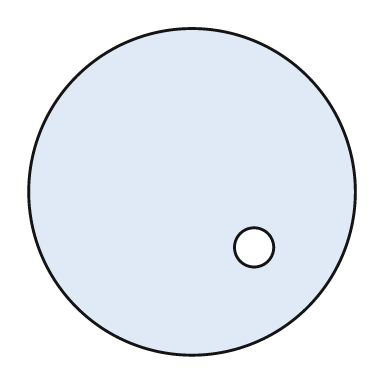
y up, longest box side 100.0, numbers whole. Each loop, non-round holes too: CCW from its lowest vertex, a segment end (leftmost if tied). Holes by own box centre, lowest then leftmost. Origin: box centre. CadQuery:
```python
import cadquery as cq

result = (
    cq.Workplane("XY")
    .moveTo(0.0, 0.0)
    .circle(50.0)
    .moveTo(19.0, -17.0)
    .circle(6.0)
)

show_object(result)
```